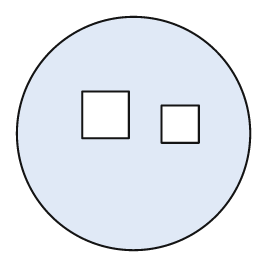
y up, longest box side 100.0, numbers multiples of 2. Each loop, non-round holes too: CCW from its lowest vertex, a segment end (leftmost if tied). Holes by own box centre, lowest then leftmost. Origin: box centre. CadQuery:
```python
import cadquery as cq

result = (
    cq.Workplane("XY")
    .moveTo(0.0, 0.0)
    .circle(50.0)
    .moveTo(12.0, -4.0)
    .lineTo(28.0, -4.0)
    .lineTo(28.0, 12.0)
    .lineTo(12.0, 12.0)
    .close()
    .moveTo(-22.0, -2.0)
    .lineTo(-2.0, -2.0)
    .lineTo(-2.0, 18.0)
    .lineTo(-22.0, 18.0)
    .close()
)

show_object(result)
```